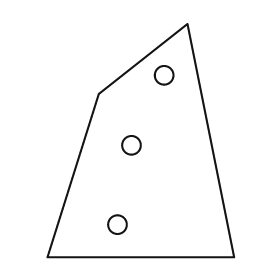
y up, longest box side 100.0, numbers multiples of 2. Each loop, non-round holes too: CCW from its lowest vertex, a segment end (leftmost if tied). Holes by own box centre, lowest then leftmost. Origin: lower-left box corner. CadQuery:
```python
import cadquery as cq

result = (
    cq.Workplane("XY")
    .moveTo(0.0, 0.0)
    .lineTo(80.0, 0.0)
    .lineTo(60.0, 100.0)
    .lineTo(22.0, 70.0)
    .close()
    .moveTo(30.0, 14.0)
    .circle(4.0)
    .moveTo(36.0, 48.0)
    .circle(4.0)
    .moveTo(50.0, 78.0)
    .circle(4.0)
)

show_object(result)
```